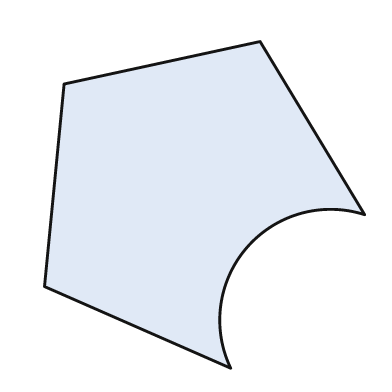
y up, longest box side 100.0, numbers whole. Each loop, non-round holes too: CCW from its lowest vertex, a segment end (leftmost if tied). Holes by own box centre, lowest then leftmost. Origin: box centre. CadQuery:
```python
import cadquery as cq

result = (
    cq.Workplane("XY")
    .moveTo(8.0, -50.0)
    .threePointArc((13.0, -13.0), (49.0, -3.0))
    .lineTo(17.0, 50.0)
    .lineTo(-43.0, 37.0)
    .lineTo(-49.0, -25.0)
    .close()
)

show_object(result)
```